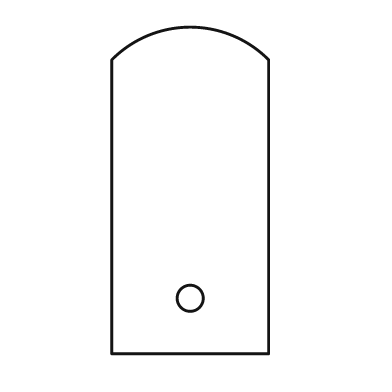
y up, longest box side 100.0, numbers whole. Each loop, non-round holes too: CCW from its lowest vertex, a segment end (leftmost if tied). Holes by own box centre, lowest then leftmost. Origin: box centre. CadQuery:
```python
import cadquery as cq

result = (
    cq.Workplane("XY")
    .moveTo(-24.0, -50.0)
    .lineTo(24.0, -50.0)
    .lineTo(24.0, 40.0)
    .threePointArc((0.0, 50.0), (-24.0, 40.0))
    .close()
    .moveTo(0.0, -33.0)
    .circle(4.0)
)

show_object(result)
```